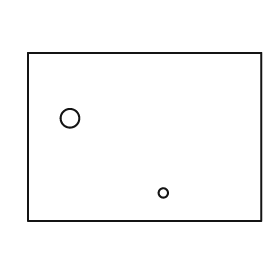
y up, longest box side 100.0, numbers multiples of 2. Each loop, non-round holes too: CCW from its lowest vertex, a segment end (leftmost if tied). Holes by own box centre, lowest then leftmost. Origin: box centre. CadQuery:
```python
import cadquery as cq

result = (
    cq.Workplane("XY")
    .moveTo(-50.0, -36.0)
    .lineTo(50.0, -36.0)
    .lineTo(50.0, 36.0)
    .lineTo(-50.0, 36.0)
    .close()
    .moveTo(8.0, -24.0)
    .circle(2.0)
    .moveTo(-32.0, 8.0)
    .circle(4.0)
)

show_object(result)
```